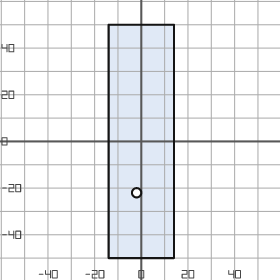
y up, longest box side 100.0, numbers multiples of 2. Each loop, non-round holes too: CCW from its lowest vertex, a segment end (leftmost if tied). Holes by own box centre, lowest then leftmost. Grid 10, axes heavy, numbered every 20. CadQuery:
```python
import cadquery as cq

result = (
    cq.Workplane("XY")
    .moveTo(-14.0, -50.0)
    .lineTo(14.0, -50.0)
    .lineTo(14.0, 50.0)
    .lineTo(-14.0, 50.0)
    .close()
    .moveTo(-2.0, -22.0)
    .circle(2.0)
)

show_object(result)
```